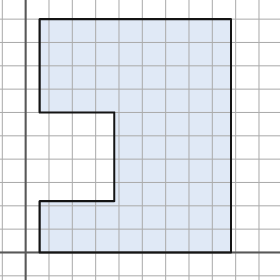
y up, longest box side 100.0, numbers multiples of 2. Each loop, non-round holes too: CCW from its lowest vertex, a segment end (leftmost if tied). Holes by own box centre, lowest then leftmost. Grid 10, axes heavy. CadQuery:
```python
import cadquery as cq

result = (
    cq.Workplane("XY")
    .moveTo(6.0, 0.0)
    .lineTo(88.0, 0.0)
    .lineTo(88.0, 100.0)
    .lineTo(6.0, 100.0)
    .lineTo(6.0, 60.0)
    .lineTo(38.0, 60.0)
    .lineTo(38.0, 22.0)
    .lineTo(6.0, 22.0)
    .close()
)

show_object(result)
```